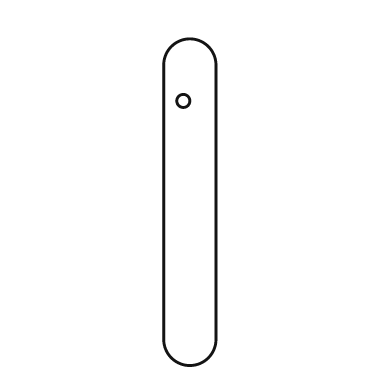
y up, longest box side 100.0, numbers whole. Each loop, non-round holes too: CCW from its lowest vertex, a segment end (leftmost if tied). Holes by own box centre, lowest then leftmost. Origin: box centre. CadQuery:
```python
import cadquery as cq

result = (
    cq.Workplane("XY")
    .moveTo(-8.0, -42.0)
    .threePointArc((0.0, -50.0), (8.0, -42.0))
    .lineTo(8.0, 42.0)
    .threePointArc((0.0, 50.0), (-8.0, 42.0))
    .close()
    .moveTo(-2.0, 31.0)
    .circle(2.0)
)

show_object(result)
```